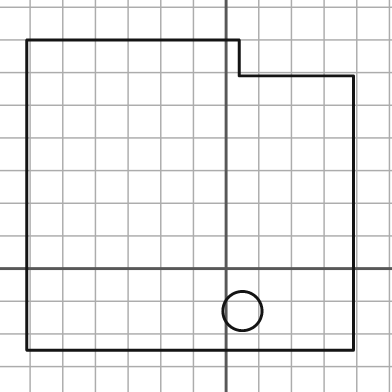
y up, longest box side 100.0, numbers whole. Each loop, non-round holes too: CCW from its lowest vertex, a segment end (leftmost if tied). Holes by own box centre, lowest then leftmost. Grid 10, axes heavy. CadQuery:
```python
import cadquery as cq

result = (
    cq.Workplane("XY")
    .moveTo(-61.0, -25.0)
    .lineTo(39.0, -25.0)
    .lineTo(39.0, 59.0)
    .lineTo(4.0, 59.0)
    .lineTo(4.0, 70.0)
    .lineTo(-61.0, 70.0)
    .close()
    .moveTo(5.0, -13.0)
    .circle(6.0)
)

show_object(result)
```